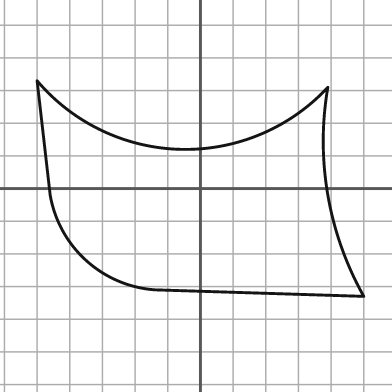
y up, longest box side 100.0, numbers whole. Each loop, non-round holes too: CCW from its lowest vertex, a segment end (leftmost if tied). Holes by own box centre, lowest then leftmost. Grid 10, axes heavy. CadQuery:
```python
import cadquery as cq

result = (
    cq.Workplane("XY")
    .moveTo(50.0, -33.0)
    .threePointArc((39.0, -2.0), (39.0, 31.0))
    .threePointArc((-6.0, 12.0), (-50.0, 33.0))
    .lineTo(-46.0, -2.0)
    .threePointArc((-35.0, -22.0), (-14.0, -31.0))
    .close()
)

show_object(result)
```